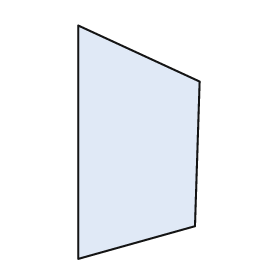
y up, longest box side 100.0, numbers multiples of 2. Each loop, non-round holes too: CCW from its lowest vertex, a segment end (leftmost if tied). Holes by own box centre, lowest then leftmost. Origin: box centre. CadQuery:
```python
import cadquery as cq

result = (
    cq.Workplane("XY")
    .moveTo(-26.0, -50.0)
    .lineTo(24.0, -36.0)
    .lineTo(26.0, 26.0)
    .lineTo(-26.0, 50.0)
    .close()
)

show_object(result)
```